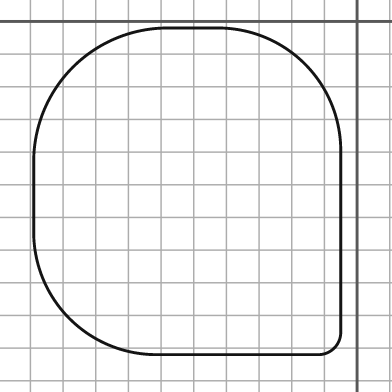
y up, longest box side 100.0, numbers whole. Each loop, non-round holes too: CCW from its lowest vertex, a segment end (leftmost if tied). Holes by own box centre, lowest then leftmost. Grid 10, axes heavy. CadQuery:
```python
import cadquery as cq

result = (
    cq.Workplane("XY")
    .moveTo(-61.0, -102.0)
    .lineTo(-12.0, -102.0)
    .threePointArc((-7.0, -100.0), (-5.0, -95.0))
    .lineTo(-5.0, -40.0)
    .threePointArc((-16.0, -13.0), (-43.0, -2.0))
    .lineTo(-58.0, -2.0)
    .threePointArc((-87.0, -14.0), (-99.0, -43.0))
    .lineTo(-99.0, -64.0)
    .threePointArc((-88.0, -91.0), (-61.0, -102.0))
    .close()
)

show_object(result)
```